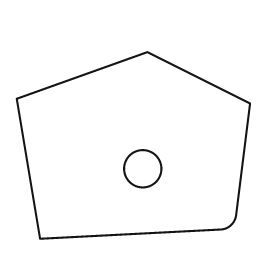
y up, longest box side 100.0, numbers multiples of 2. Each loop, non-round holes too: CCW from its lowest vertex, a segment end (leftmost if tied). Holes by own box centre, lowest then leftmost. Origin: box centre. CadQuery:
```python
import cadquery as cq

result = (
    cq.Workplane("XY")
    .moveTo(-40.0, -40.0)
    .lineTo(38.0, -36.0)
    .threePointArc((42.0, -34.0), (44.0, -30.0))
    .lineTo(50.0, 18.0)
    .lineTo(6.0, 40.0)
    .lineTo(-50.0, 20.0)
    .close()
    .moveTo(4.0, -10.0)
    .circle(8.0)
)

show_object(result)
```